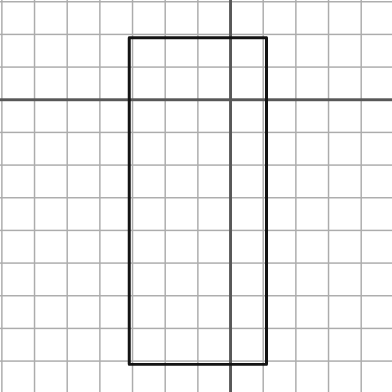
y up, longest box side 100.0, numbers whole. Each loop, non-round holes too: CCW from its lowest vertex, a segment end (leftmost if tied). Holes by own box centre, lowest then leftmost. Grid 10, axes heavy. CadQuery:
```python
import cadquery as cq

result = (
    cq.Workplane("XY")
    .moveTo(-31.0, -81.0)
    .lineTo(11.0, -81.0)
    .lineTo(11.0, 19.0)
    .lineTo(-31.0, 19.0)
    .close()
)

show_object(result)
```